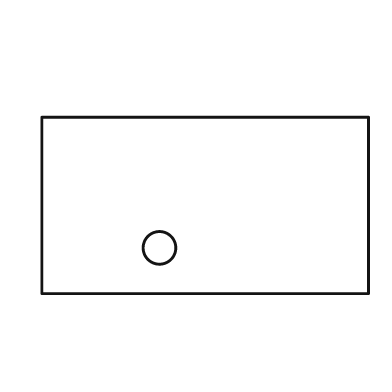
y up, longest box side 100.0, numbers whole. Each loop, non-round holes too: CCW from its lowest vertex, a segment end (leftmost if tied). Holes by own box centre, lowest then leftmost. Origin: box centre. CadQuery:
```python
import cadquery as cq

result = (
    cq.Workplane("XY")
    .moveTo(-50.0, -27.0)
    .lineTo(50.0, -27.0)
    .lineTo(50.0, 27.0)
    .lineTo(-50.0, 27.0)
    .close()
    .moveTo(-14.0, -13.0)
    .circle(5.0)
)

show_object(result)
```